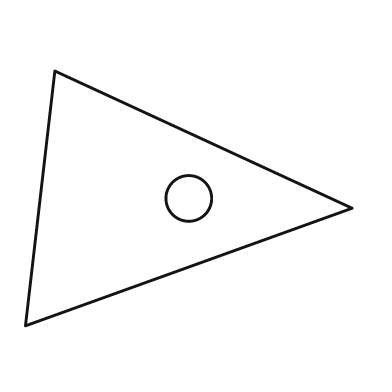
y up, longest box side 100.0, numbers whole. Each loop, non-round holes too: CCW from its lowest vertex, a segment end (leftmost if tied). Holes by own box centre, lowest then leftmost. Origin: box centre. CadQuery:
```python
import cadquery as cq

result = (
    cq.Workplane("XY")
    .moveTo(-50.0, -39.0)
    .lineTo(50.0, -3.0)
    .lineTo(-41.0, 39.0)
    .close()
    .moveTo(0.0, 0.0)
    .circle(7.0)
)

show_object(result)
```